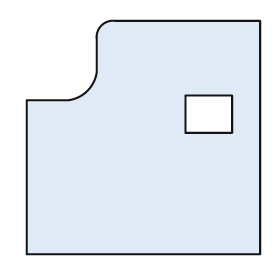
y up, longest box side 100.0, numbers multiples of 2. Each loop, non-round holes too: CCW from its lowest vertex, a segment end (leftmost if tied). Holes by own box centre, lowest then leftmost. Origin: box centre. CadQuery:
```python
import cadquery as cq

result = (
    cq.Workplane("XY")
    .moveTo(-50.0, -50.0)
    .lineTo(50.0, -50.0)
    .lineTo(50.0, 50.0)
    .lineTo(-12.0, 50.0)
    .threePointArc((-18.0, 48.0), (-20.0, 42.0))
    .lineTo(-20.0, 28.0)
    .threePointArc((-24.0, 20.0), (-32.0, 16.0))
    .lineTo(-50.0, 16.0)
    .close()
    .moveTo(18.0, 2.0)
    .lineTo(38.0, 2.0)
    .lineTo(38.0, 18.0)
    .lineTo(18.0, 18.0)
    .close()
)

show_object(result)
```